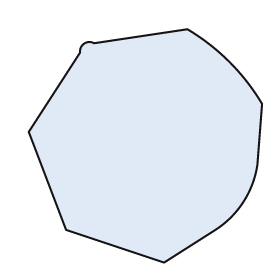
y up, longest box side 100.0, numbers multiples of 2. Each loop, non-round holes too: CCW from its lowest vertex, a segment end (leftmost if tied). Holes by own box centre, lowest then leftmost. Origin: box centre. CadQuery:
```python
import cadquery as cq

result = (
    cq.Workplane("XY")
    .moveTo(8.0, -50.0)
    .lineTo(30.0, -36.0)
    .threePointArc((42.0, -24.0), (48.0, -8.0))
    .lineTo(50.0, 18.0)
    .threePointArc((36.0, 36.0), (18.0, 50.0))
    .lineTo(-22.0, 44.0)
    .threePointArc((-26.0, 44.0), (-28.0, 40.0))
    .lineTo(-50.0, 6.0)
    .lineTo(-34.0, -36.0)
    .close()
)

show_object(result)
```